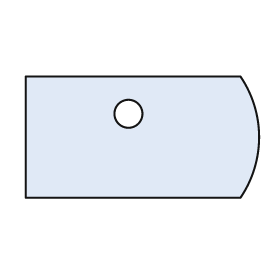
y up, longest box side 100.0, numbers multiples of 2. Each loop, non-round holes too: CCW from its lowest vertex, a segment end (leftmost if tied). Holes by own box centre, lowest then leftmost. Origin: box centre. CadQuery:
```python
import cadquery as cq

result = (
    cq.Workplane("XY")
    .moveTo(-50.0, -26.0)
    .lineTo(42.0, -26.0)
    .threePointArc((50.0, 0.0), (42.0, 26.0))
    .lineTo(-50.0, 26.0)
    .close()
    .moveTo(-6.0, 10.0)
    .circle(6.0)
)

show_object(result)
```